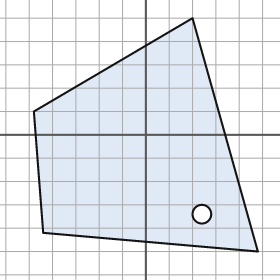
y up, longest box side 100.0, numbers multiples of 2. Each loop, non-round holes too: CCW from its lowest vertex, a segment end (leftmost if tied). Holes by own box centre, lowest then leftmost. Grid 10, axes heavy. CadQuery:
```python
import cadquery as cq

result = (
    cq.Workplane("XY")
    .moveTo(48.0, -50.0)
    .lineTo(20.0, 50.0)
    .lineTo(-48.0, 10.0)
    .lineTo(-44.0, -42.0)
    .close()
    .moveTo(24.0, -34.0)
    .circle(4.0)
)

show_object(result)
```